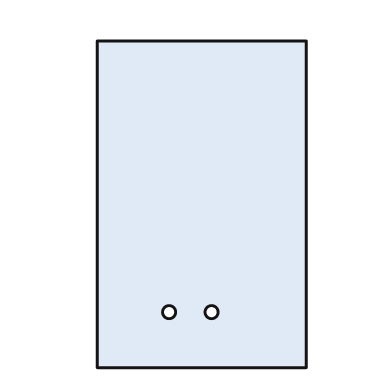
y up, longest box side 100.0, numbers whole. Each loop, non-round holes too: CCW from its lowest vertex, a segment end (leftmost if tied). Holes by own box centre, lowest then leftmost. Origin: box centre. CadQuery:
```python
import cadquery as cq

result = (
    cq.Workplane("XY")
    .moveTo(-32.0, -50.0)
    .lineTo(32.0, -50.0)
    .lineTo(32.0, 50.0)
    .lineTo(-32.0, 50.0)
    .close()
    .moveTo(-10.0, -33.0)
    .circle(2.0)
    .moveTo(3.0, -33.0)
    .circle(2.0)
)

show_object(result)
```